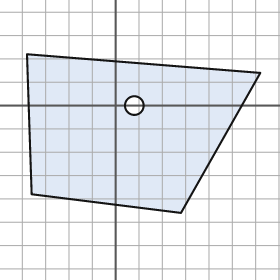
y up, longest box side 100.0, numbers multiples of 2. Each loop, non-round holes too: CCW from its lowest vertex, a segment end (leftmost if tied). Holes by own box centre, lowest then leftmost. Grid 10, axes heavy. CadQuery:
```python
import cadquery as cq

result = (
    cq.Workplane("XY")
    .moveTo(28.0, -46.0)
    .lineTo(62.0, 14.0)
    .lineTo(-38.0, 22.0)
    .lineTo(-36.0, -38.0)
    .close()
    .moveTo(8.0, 0.0)
    .circle(4.0)
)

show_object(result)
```